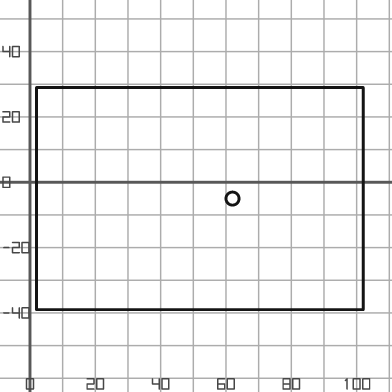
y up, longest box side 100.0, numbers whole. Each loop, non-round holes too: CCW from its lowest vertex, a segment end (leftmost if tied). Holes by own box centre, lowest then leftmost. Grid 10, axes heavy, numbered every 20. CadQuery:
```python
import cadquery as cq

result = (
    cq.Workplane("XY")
    .moveTo(2.0, -39.0)
    .lineTo(102.0, -39.0)
    .lineTo(102.0, 29.0)
    .lineTo(2.0, 29.0)
    .close()
    .moveTo(62.0, -5.0)
    .circle(2.0)
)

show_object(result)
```